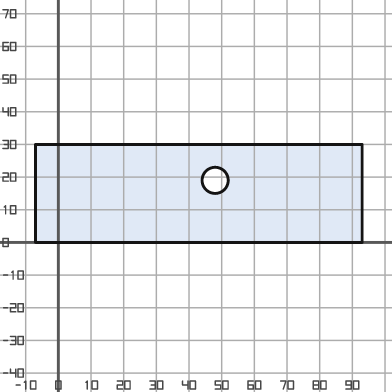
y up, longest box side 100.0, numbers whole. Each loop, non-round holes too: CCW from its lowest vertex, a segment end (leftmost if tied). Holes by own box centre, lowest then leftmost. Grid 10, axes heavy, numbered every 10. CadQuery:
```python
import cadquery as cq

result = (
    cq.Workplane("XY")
    .moveTo(-7.0, 0.0)
    .lineTo(93.0, 0.0)
    .lineTo(93.0, 30.0)
    .lineTo(-7.0, 30.0)
    .close()
    .moveTo(48.0, 19.0)
    .circle(4.0)
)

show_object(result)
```